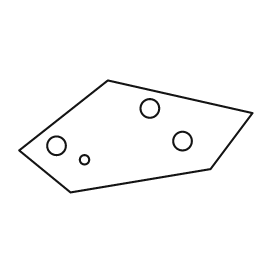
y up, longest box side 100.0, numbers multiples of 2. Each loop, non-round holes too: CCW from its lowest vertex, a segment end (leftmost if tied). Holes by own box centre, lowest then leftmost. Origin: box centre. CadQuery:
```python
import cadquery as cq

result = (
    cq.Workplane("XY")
    .moveTo(-28.0, -24.0)
    .lineTo(32.0, -14.0)
    .lineTo(50.0, 10.0)
    .lineTo(-12.0, 24.0)
    .lineTo(-50.0, -6.0)
    .close()
    .moveTo(-22.0, -10.0)
    .circle(2.0)
    .moveTo(-34.0, -4.0)
    .circle(4.0)
    .moveTo(20.0, -2.0)
    .circle(4.0)
    .moveTo(6.0, 12.0)
    .circle(4.0)
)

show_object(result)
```